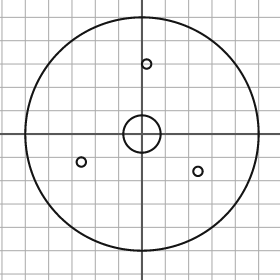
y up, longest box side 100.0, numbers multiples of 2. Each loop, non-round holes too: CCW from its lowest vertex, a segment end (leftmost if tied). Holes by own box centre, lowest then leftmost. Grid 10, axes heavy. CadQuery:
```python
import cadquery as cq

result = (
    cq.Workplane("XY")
    .moveTo(0.0, 0.0)
    .circle(50.0)
    .moveTo(24.0, -16.0)
    .circle(2.0)
    .moveTo(-26.0, -12.0)
    .circle(2.0)
    .moveTo(0.0, 0.0)
    .circle(8.0)
    .moveTo(2.0, 30.0)
    .circle(2.0)
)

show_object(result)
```